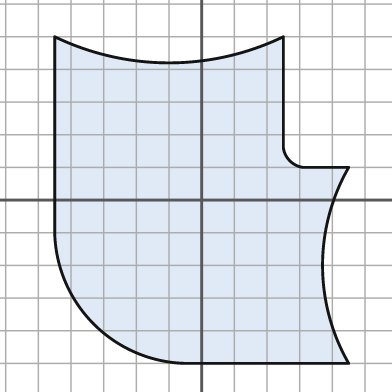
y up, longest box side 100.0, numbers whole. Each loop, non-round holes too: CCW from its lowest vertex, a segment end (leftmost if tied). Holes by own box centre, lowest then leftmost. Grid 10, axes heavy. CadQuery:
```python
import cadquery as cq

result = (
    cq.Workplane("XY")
    .moveTo(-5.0, -50.0)
    .lineTo(45.0, -50.0)
    .threePointArc((37.0, -20.0), (45.0, 10.0))
    .lineTo(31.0, 10.0)
    .threePointArc((27.0, 12.0), (25.0, 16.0))
    .lineTo(25.0, 50.0)
    .threePointArc((-10.0, 42.0), (-45.0, 50.0))
    .lineTo(-45.0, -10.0)
    .threePointArc((-33.0, -38.0), (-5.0, -50.0))
    .close()
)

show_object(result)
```